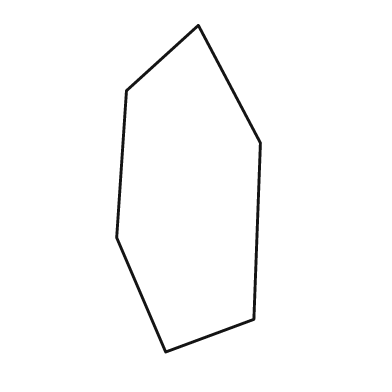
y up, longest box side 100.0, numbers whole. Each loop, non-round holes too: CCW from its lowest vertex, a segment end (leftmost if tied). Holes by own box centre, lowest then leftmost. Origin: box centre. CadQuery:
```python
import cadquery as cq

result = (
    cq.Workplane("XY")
    .moveTo(-7.0, -50.0)
    .lineTo(20.0, -40.0)
    .lineTo(22.0, 14.0)
    .lineTo(3.0, 50.0)
    .lineTo(-19.0, 30.0)
    .lineTo(-22.0, -15.0)
    .close()
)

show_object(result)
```